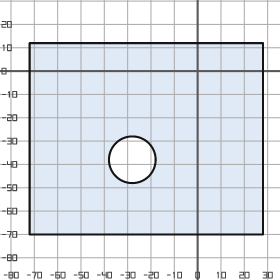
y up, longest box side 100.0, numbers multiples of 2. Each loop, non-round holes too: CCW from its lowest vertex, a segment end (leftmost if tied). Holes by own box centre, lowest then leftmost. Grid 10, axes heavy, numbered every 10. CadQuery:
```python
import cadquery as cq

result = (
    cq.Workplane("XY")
    .moveTo(-72.0, -70.0)
    .lineTo(28.0, -70.0)
    .lineTo(28.0, 12.0)
    .lineTo(-72.0, 12.0)
    .close()
    .moveTo(-28.0, -38.0)
    .circle(10.0)
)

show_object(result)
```